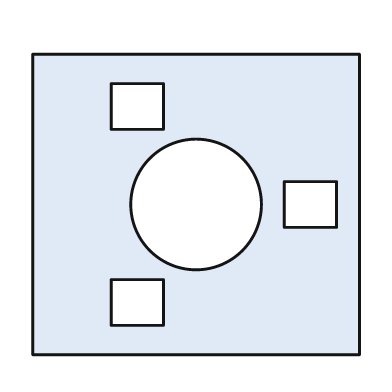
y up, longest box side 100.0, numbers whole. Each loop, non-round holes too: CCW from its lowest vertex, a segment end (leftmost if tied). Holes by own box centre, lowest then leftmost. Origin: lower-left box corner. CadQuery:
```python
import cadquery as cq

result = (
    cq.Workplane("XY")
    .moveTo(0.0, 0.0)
    .lineTo(100.0, 0.0)
    .lineTo(100.0, 92.0)
    .lineTo(0.0, 92.0)
    .close()
    .moveTo(24.0, 9.0)
    .lineTo(40.0, 9.0)
    .lineTo(40.0, 23.0)
    .lineTo(24.0, 23.0)
    .close()
    .moveTo(50.0, 46.0)
    .circle(20.0)
    .moveTo(77.0, 39.0)
    .lineTo(93.0, 39.0)
    .lineTo(93.0, 53.0)
    .lineTo(77.0, 53.0)
    .close()
    .moveTo(24.0, 69.0)
    .lineTo(40.0, 69.0)
    .lineTo(40.0, 83.0)
    .lineTo(24.0, 83.0)
    .close()
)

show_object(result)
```